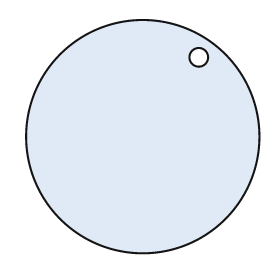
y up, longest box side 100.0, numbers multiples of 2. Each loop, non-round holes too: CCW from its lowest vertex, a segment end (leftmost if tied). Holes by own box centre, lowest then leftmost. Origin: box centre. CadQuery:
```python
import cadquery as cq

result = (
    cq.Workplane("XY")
    .moveTo(0.0, 0.0)
    .circle(50.0)
    .moveTo(24.0, 34.0)
    .circle(4.0)
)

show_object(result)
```